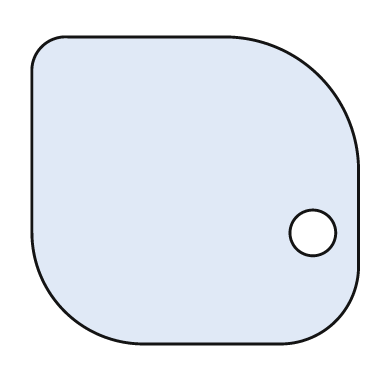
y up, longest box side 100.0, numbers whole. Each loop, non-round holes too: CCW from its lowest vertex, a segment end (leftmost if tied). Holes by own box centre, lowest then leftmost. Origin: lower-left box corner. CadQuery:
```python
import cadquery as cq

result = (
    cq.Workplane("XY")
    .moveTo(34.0, 0.0)
    .lineTo(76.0, 0.0)
    .threePointArc((93.0, 7.0), (100.0, 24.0))
    .lineTo(100.0, 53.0)
    .threePointArc((88.0, 82.0), (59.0, 94.0))
    .lineTo(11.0, 94.0)
    .threePointArc((3.0, 91.0), (0.0, 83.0))
    .lineTo(0.0, 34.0)
    .threePointArc((10.0, 10.0), (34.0, 0.0))
    .close()
    .moveTo(86.0, 34.0)
    .circle(7.0)
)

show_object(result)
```